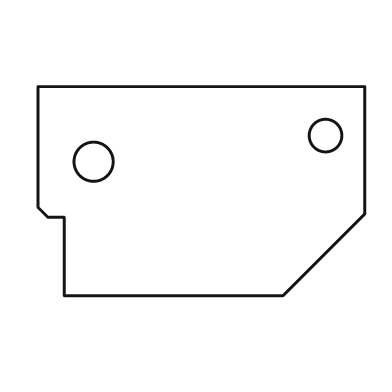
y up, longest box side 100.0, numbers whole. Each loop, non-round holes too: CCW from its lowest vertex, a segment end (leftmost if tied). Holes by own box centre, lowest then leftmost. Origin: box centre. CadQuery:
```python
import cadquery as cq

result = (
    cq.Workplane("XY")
    .moveTo(-42.0, -32.0)
    .lineTo(25.0, -32.0)
    .lineTo(50.0, -7.0)
    .lineTo(50.0, 32.0)
    .lineTo(-50.0, 32.0)
    .lineTo(-50.0, -5.0)
    .lineTo(-47.0, -8.0)
    .lineTo(-42.0, -8.0)
    .close()
    .moveTo(-33.0, 9.0)
    .circle(6.0)
    .moveTo(38.0, 17.0)
    .circle(5.0)
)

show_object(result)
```